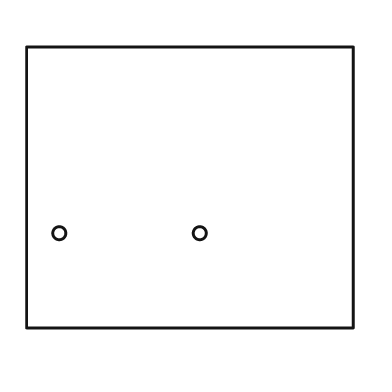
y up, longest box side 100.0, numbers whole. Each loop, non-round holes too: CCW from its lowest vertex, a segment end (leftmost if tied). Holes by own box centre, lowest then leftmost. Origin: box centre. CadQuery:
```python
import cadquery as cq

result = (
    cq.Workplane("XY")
    .moveTo(-50.0, -43.0)
    .lineTo(50.0, -43.0)
    .lineTo(50.0, 43.0)
    .lineTo(-50.0, 43.0)
    .close()
    .moveTo(-40.0, -14.0)
    .circle(2.0)
    .moveTo(3.0, -14.0)
    .circle(2.0)
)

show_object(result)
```